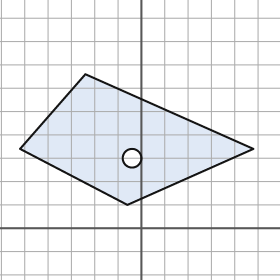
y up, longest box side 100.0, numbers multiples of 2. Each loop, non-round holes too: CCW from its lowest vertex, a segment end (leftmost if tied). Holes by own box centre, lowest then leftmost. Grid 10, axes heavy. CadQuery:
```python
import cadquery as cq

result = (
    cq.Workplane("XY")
    .moveTo(-6.0, 10.0)
    .lineTo(48.0, 34.0)
    .lineTo(-24.0, 66.0)
    .lineTo(-52.0, 34.0)
    .close()
    .moveTo(-4.0, 30.0)
    .circle(4.0)
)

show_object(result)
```